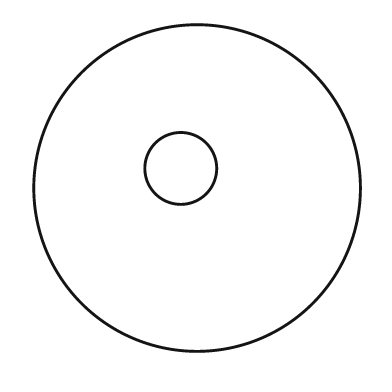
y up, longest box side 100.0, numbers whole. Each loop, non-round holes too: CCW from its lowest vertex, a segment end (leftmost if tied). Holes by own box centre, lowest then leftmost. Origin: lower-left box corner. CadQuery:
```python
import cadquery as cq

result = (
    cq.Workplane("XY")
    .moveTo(50.0, 50.0)
    .circle(50.0)
    .moveTo(45.0, 56.0)
    .circle(11.0)
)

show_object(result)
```